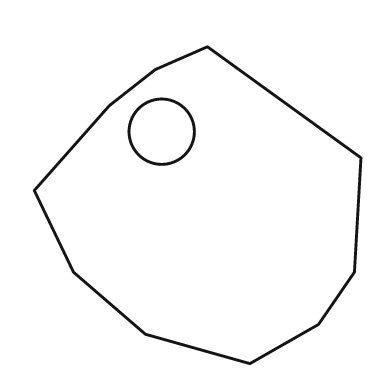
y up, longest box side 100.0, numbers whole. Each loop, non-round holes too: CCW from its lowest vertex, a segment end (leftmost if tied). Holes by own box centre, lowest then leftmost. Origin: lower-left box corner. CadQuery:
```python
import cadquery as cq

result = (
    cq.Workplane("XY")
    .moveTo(66.0, 0.0)
    .lineTo(87.0, 12.0)
    .lineTo(98.0, 28.0)
    .lineTo(100.0, 63.0)
    .lineTo(53.0, 97.0)
    .lineTo(37.0, 90.0)
    .lineTo(23.0, 79.0)
    .lineTo(0.0, 53.0)
    .lineTo(12.0, 28.0)
    .lineTo(34.0, 9.0)
    .close()
    .moveTo(39.0, 71.0)
    .circle(10.0)
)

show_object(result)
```